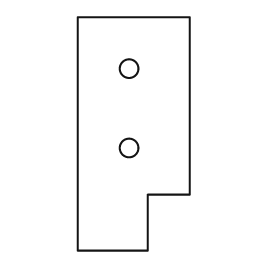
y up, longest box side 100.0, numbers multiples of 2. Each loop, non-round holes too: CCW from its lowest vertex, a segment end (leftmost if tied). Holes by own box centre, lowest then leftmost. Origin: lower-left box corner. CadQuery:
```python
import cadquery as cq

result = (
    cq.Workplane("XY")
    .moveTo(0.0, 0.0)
    .lineTo(30.0, 0.0)
    .lineTo(30.0, 24.0)
    .lineTo(48.0, 24.0)
    .lineTo(48.0, 100.0)
    .lineTo(0.0, 100.0)
    .close()
    .moveTo(22.0, 44.0)
    .circle(4.0)
    .moveTo(22.0, 78.0)
    .circle(4.0)
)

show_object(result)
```